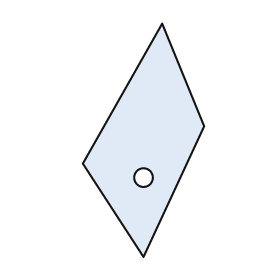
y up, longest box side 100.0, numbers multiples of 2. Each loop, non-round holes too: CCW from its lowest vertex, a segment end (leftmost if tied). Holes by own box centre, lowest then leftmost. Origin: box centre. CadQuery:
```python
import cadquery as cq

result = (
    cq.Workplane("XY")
    .moveTo(0.0, -50.0)
    .lineTo(26.0, 6.0)
    .lineTo(8.0, 50.0)
    .lineTo(-26.0, -10.0)
    .close()
    .moveTo(0.0, -16.0)
    .circle(4.0)
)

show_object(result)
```